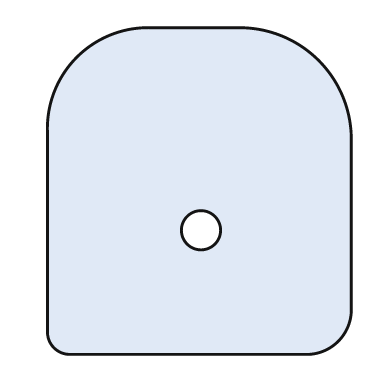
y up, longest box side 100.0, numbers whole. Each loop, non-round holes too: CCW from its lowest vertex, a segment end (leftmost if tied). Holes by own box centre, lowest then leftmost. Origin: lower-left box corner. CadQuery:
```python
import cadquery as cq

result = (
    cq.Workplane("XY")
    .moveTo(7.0, 0.0)
    .lineTo(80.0, 0.0)
    .threePointArc((89.0, 4.0), (93.0, 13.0))
    .lineTo(93.0, 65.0)
    .threePointArc((83.0, 90.0), (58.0, 100.0))
    .lineTo(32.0, 100.0)
    .threePointArc((9.0, 91.0), (0.0, 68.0))
    .lineTo(0.0, 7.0)
    .threePointArc((2.0, 2.0), (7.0, 0.0))
    .close()
    .moveTo(47.0, 38.0)
    .circle(6.0)
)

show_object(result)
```